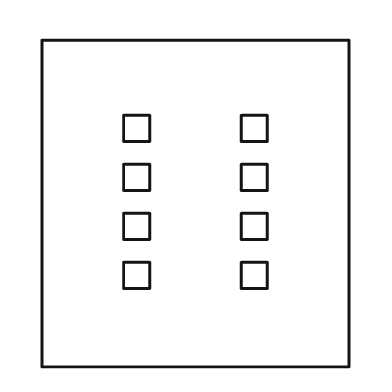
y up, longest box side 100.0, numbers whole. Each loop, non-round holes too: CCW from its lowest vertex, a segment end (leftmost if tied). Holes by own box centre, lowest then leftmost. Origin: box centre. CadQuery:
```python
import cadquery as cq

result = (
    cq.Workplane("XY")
    .moveTo(-47.0, -50.0)
    .lineTo(47.0, -50.0)
    .lineTo(47.0, 50.0)
    .lineTo(-47.0, 50.0)
    .close()
    .moveTo(-22.0, -26.0)
    .lineTo(-14.0, -26.0)
    .lineTo(-14.0, -18.0)
    .lineTo(-22.0, -18.0)
    .close()
    .moveTo(14.0, -26.0)
    .lineTo(22.0, -26.0)
    .lineTo(22.0, -18.0)
    .lineTo(14.0, -18.0)
    .close()
    .moveTo(-22.0, -11.0)
    .lineTo(-14.0, -11.0)
    .lineTo(-14.0, -3.0)
    .lineTo(-22.0, -3.0)
    .close()
    .moveTo(14.0, -11.0)
    .lineTo(22.0, -11.0)
    .lineTo(22.0, -3.0)
    .lineTo(14.0, -3.0)
    .close()
    .moveTo(-22.0, 4.0)
    .lineTo(-14.0, 4.0)
    .lineTo(-14.0, 12.0)
    .lineTo(-22.0, 12.0)
    .close()
    .moveTo(14.0, 4.0)
    .lineTo(22.0, 4.0)
    .lineTo(22.0, 12.0)
    .lineTo(14.0, 12.0)
    .close()
    .moveTo(-22.0, 19.0)
    .lineTo(-14.0, 19.0)
    .lineTo(-14.0, 27.0)
    .lineTo(-22.0, 27.0)
    .close()
    .moveTo(14.0, 19.0)
    .lineTo(22.0, 19.0)
    .lineTo(22.0, 27.0)
    .lineTo(14.0, 27.0)
    .close()
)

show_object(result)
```